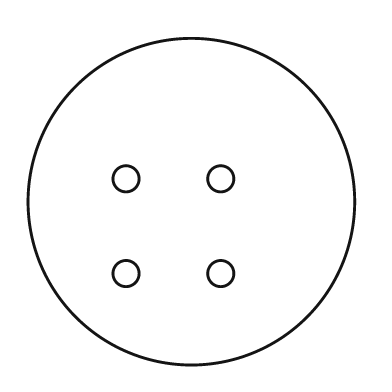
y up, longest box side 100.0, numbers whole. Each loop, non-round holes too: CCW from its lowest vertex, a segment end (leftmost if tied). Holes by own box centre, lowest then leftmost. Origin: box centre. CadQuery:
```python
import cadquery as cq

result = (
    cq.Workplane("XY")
    .moveTo(0.0, 0.0)
    .circle(50.0)
    .moveTo(-20.0, -22.0)
    .circle(4.0)
    .moveTo(9.0, -22.0)
    .circle(4.0)
    .moveTo(-20.0, 7.0)
    .circle(4.0)
    .moveTo(9.0, 7.0)
    .circle(4.0)
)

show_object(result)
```